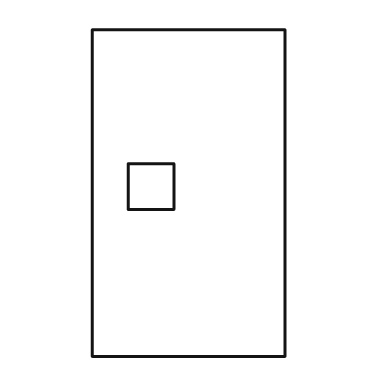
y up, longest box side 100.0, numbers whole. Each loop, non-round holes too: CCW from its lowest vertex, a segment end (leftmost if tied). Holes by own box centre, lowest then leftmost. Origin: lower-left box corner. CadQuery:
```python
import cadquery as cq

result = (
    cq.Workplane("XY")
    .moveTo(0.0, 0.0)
    .lineTo(59.0, 0.0)
    .lineTo(59.0, 100.0)
    .lineTo(0.0, 100.0)
    .close()
    .moveTo(11.0, 45.0)
    .lineTo(25.0, 45.0)
    .lineTo(25.0, 59.0)
    .lineTo(11.0, 59.0)
    .close()
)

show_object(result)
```